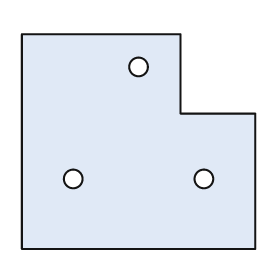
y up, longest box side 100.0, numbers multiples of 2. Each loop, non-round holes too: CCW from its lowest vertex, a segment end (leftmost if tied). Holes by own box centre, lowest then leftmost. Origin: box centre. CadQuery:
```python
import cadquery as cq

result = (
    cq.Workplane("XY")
    .moveTo(-50.0, -46.0)
    .lineTo(50.0, -46.0)
    .lineTo(50.0, 12.0)
    .lineTo(18.0, 12.0)
    .lineTo(18.0, 46.0)
    .lineTo(-50.0, 46.0)
    .close()
    .moveTo(-28.0, -16.0)
    .circle(4.0)
    .moveTo(28.0, -16.0)
    .circle(4.0)
    .moveTo(0.0, 32.0)
    .circle(4.0)
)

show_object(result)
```